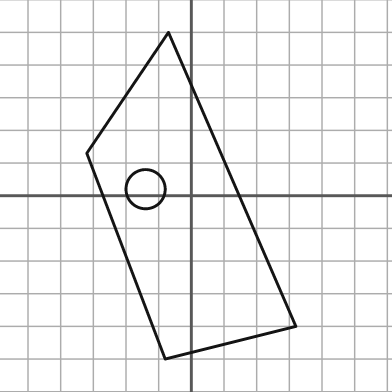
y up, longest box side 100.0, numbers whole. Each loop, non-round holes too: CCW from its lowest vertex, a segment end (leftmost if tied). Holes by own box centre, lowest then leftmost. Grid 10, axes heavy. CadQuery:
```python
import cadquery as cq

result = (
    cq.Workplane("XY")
    .moveTo(-8.0, -50.0)
    .lineTo(32.0, -40.0)
    .lineTo(-7.0, 50.0)
    .lineTo(-32.0, 13.0)
    .close()
    .moveTo(-14.0, 2.0)
    .circle(6.0)
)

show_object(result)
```